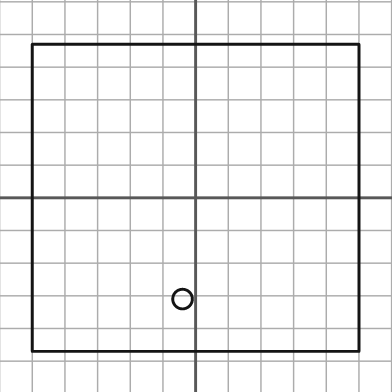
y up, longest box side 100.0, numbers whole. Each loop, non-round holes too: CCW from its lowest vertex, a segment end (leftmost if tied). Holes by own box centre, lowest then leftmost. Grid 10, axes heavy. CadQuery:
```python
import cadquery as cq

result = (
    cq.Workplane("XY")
    .moveTo(-50.0, -47.0)
    .lineTo(50.0, -47.0)
    .lineTo(50.0, 47.0)
    .lineTo(-50.0, 47.0)
    .close()
    .moveTo(-4.0, -31.0)
    .circle(3.0)
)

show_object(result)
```